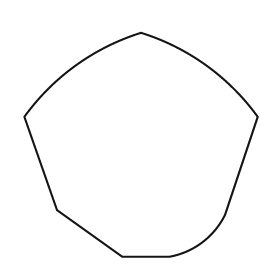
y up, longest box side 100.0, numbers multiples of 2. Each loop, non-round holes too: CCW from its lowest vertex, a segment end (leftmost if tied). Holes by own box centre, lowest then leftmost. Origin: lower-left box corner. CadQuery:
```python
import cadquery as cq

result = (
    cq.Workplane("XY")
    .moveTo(42.0, 0.0)
    .lineTo(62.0, 0.0)
    .threePointArc((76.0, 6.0), (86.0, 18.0))
    .lineTo(100.0, 60.0)
    .threePointArc((78.0, 82.0), (50.0, 96.0))
    .threePointArc((22.0, 82.0), (0.0, 60.0))
    .lineTo(14.0, 20.0)
    .close()
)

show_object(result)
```